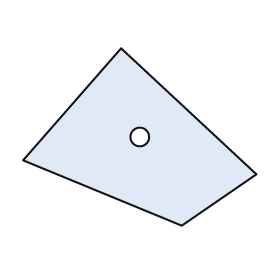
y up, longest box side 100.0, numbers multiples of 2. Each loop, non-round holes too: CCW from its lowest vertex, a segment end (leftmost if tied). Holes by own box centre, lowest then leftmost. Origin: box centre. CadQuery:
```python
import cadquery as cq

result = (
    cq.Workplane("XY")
    .moveTo(18.0, -38.0)
    .lineTo(50.0, -16.0)
    .lineTo(-8.0, 38.0)
    .lineTo(-50.0, -10.0)
    .close()
    .moveTo(0.0, 0.0)
    .circle(4.0)
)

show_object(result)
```